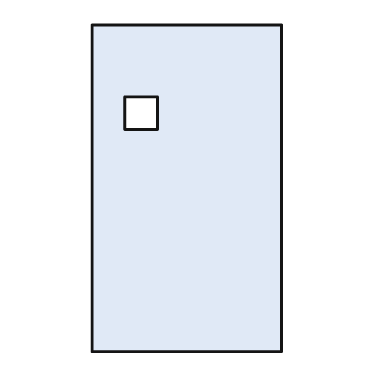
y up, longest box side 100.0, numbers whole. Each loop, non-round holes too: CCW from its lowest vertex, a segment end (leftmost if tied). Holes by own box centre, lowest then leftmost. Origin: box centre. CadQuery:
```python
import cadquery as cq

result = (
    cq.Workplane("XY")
    .moveTo(-29.0, -50.0)
    .lineTo(29.0, -50.0)
    .lineTo(29.0, 50.0)
    .lineTo(-29.0, 50.0)
    .close()
    .moveTo(-19.0, 18.0)
    .lineTo(-9.0, 18.0)
    .lineTo(-9.0, 28.0)
    .lineTo(-19.0, 28.0)
    .close()
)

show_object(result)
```